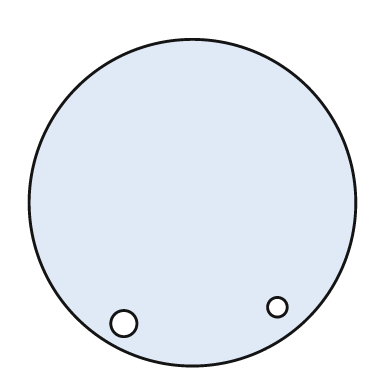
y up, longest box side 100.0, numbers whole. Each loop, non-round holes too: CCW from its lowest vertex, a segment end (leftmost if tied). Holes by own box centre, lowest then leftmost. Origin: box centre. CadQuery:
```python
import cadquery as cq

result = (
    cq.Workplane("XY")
    .moveTo(0.0, 0.0)
    .circle(50.0)
    .moveTo(-21.0, -37.0)
    .circle(4.0)
    .moveTo(26.0, -32.0)
    .circle(3.0)
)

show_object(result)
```